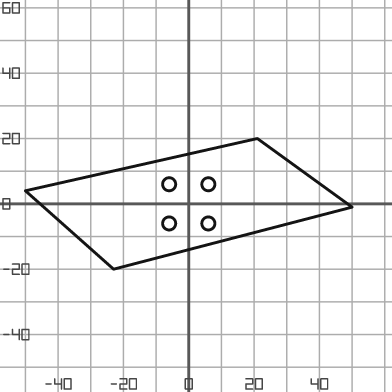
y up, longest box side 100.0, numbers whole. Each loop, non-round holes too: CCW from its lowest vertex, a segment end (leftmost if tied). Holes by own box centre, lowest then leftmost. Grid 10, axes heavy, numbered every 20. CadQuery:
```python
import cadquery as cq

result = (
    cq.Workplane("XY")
    .moveTo(-23.0, -20.0)
    .lineTo(50.0, -1.0)
    .lineTo(21.0, 20.0)
    .lineTo(-50.0, 4.0)
    .close()
    .moveTo(-6.0, -6.0)
    .circle(2.0)
    .moveTo(6.0, -6.0)
    .circle(2.0)
    .moveTo(-6.0, 6.0)
    .circle(2.0)
    .moveTo(6.0, 6.0)
    .circle(2.0)
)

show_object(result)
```